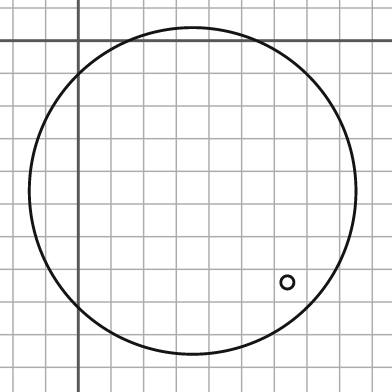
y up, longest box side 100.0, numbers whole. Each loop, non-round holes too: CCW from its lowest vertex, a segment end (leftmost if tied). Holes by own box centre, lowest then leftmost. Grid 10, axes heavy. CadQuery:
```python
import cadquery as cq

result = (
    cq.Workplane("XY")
    .moveTo(35.0, -46.0)
    .circle(50.0)
    .moveTo(64.0, -74.0)
    .circle(2.0)
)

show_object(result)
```